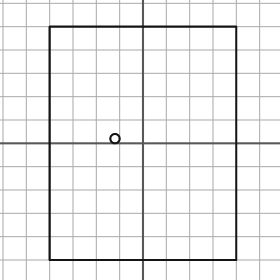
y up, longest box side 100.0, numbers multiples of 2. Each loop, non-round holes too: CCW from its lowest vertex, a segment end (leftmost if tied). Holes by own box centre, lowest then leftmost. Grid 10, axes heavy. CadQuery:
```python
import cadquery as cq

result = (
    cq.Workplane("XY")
    .moveTo(-40.0, -50.0)
    .lineTo(40.0, -50.0)
    .lineTo(40.0, 50.0)
    .lineTo(-40.0, 50.0)
    .close()
    .moveTo(-12.0, 2.0)
    .circle(2.0)
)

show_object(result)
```